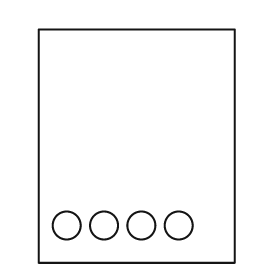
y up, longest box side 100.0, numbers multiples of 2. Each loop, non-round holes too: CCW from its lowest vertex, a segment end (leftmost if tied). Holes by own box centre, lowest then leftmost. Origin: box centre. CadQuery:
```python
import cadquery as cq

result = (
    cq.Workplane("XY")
    .moveTo(-42.0, -50.0)
    .lineTo(42.0, -50.0)
    .lineTo(42.0, 50.0)
    .lineTo(-42.0, 50.0)
    .close()
    .moveTo(-30.0, -34.0)
    .circle(6.0)
    .moveTo(-14.0, -34.0)
    .circle(6.0)
    .moveTo(2.0, -34.0)
    .circle(6.0)
    .moveTo(18.0, -34.0)
    .circle(6.0)
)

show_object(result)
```